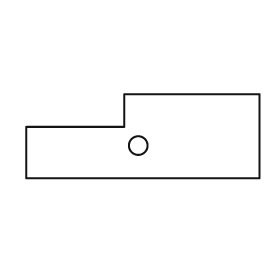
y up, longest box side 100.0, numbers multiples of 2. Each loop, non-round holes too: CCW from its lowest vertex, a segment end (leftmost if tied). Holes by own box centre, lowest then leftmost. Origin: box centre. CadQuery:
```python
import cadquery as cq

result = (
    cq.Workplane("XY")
    .moveTo(-50.0, -18.0)
    .lineTo(50.0, -18.0)
    .lineTo(50.0, 18.0)
    .lineTo(-8.0, 18.0)
    .lineTo(-8.0, 4.0)
    .lineTo(-50.0, 4.0)
    .close()
    .moveTo(-2.0, -4.0)
    .circle(4.0)
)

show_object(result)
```